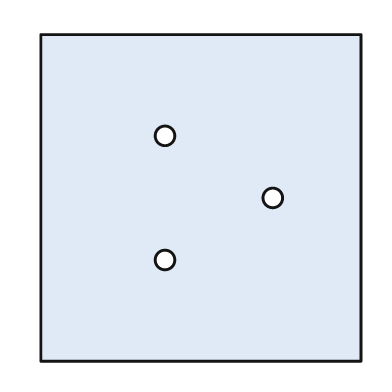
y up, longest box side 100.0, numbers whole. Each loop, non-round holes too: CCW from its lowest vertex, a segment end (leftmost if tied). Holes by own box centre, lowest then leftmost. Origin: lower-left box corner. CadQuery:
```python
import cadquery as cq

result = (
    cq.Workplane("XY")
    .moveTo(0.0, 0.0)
    .lineTo(98.0, 0.0)
    .lineTo(98.0, 100.0)
    .lineTo(0.0, 100.0)
    .close()
    .moveTo(38.0, 31.0)
    .circle(3.0)
    .moveTo(71.0, 50.0)
    .circle(3.0)
    .moveTo(38.0, 69.0)
    .circle(3.0)
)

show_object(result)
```